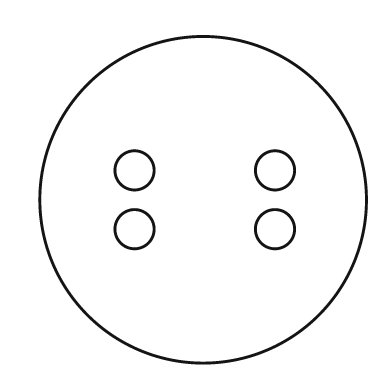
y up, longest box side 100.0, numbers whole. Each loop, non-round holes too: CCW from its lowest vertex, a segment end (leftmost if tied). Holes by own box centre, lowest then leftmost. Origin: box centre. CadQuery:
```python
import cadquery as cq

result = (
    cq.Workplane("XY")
    .moveTo(0.0, 0.0)
    .circle(50.0)
    .moveTo(-21.0, -9.0)
    .circle(6.0)
    .moveTo(22.0, -9.0)
    .circle(6.0)
    .moveTo(-21.0, 9.0)
    .circle(6.0)
    .moveTo(22.0, 9.0)
    .circle(6.0)
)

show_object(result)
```